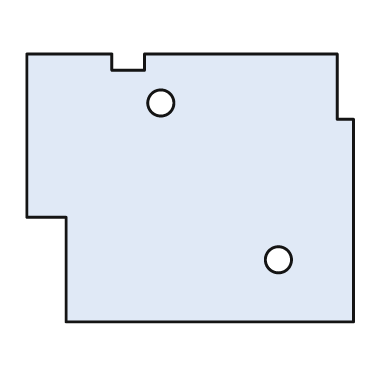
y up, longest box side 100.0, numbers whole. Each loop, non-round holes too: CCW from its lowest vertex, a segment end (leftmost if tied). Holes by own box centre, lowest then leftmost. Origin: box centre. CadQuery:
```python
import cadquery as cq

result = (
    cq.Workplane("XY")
    .moveTo(-38.0, -41.0)
    .lineTo(50.0, -41.0)
    .lineTo(50.0, 21.0)
    .lineTo(45.0, 21.0)
    .lineTo(45.0, 41.0)
    .lineTo(-14.0, 41.0)
    .lineTo(-14.0, 36.0)
    .lineTo(-24.0, 36.0)
    .lineTo(-24.0, 41.0)
    .lineTo(-50.0, 41.0)
    .lineTo(-50.0, -9.0)
    .lineTo(-38.0, -9.0)
    .close()
    .moveTo(27.0, -22.0)
    .circle(4.0)
    .moveTo(-9.0, 26.0)
    .circle(4.0)
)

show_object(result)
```